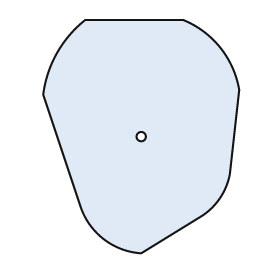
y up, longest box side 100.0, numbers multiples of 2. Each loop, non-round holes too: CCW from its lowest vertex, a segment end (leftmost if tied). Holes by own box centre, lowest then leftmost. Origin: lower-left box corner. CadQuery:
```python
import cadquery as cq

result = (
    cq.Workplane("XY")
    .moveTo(42.0, 0.0)
    .lineTo(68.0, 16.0)
    .threePointArc((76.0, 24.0), (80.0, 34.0))
    .lineTo(84.0, 70.0)
    .threePointArc((76.0, 88.0), (60.0, 100.0))
    .lineTo(18.0, 100.0)
    .threePointArc((6.0, 86.0), (0.0, 68.0))
    .lineTo(16.0, 20.0)
    .threePointArc((26.0, 6.0), (42.0, 0.0))
    .close()
    .moveTo(42.0, 50.0)
    .circle(2.0)
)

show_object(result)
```